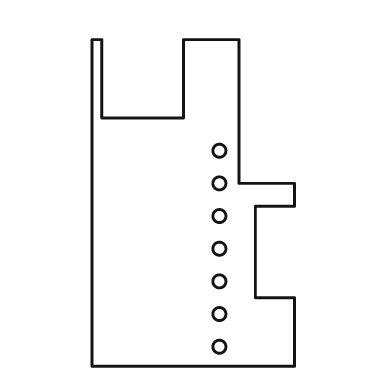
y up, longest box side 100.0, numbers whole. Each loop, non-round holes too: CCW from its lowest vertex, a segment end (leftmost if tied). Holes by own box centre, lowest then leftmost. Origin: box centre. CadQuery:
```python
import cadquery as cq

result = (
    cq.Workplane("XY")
    .moveTo(-31.0, -50.0)
    .lineTo(31.0, -50.0)
    .lineTo(31.0, -29.0)
    .lineTo(19.0, -29.0)
    .lineTo(19.0, -1.0)
    .lineTo(31.0, -1.0)
    .lineTo(31.0, 6.0)
    .lineTo(14.0, 6.0)
    .lineTo(14.0, 50.0)
    .lineTo(-3.0, 50.0)
    .lineTo(-3.0, 26.0)
    .lineTo(-28.0, 26.0)
    .lineTo(-28.0, 50.0)
    .lineTo(-31.0, 50.0)
    .close()
    .moveTo(8.0, -44.0)
    .circle(2.0)
    .moveTo(8.0, -34.0)
    .circle(2.0)
    .moveTo(8.0, -24.0)
    .circle(2.0)
    .moveTo(8.0, -14.0)
    .circle(2.0)
    .moveTo(8.0, -4.0)
    .circle(2.0)
    .moveTo(8.0, 6.0)
    .circle(2.0)
    .moveTo(8.0, 16.0)
    .circle(2.0)
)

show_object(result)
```